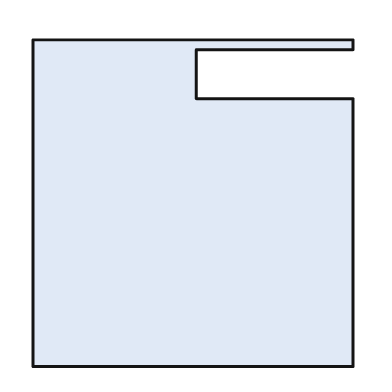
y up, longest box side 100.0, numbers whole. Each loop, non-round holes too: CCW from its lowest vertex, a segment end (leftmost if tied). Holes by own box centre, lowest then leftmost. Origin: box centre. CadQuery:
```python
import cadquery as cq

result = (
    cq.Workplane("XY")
    .moveTo(-49.0, -50.0)
    .lineTo(49.0, -50.0)
    .lineTo(49.0, 32.0)
    .lineTo(1.0, 32.0)
    .lineTo(1.0, 47.0)
    .lineTo(49.0, 47.0)
    .lineTo(49.0, 50.0)
    .lineTo(-49.0, 50.0)
    .close()
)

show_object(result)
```